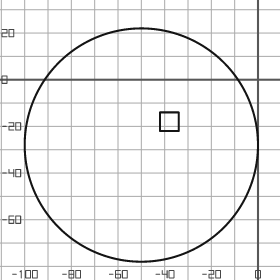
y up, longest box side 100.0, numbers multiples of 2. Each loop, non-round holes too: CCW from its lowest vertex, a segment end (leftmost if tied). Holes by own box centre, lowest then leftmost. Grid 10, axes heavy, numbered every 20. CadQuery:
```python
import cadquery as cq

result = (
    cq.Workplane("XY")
    .moveTo(-50.0, -28.0)
    .circle(50.0)
    .moveTo(-42.0, -22.0)
    .lineTo(-34.0, -22.0)
    .lineTo(-34.0, -14.0)
    .lineTo(-42.0, -14.0)
    .close()
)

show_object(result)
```